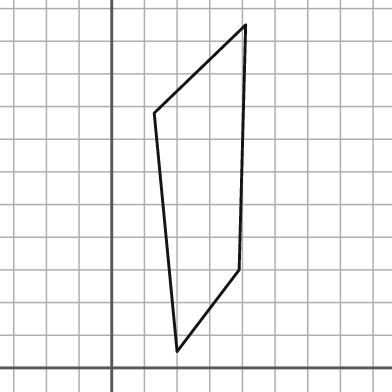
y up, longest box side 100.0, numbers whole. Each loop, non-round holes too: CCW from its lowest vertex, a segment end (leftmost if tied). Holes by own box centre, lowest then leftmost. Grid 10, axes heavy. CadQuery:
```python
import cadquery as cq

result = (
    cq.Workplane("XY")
    .moveTo(20.0, 5.0)
    .lineTo(39.0, 30.0)
    .lineTo(41.0, 105.0)
    .lineTo(13.0, 78.0)
    .close()
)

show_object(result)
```